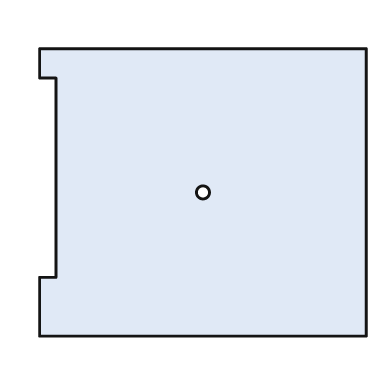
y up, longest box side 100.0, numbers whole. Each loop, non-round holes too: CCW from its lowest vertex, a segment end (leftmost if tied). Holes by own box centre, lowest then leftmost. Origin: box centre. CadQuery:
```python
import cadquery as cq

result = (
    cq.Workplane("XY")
    .moveTo(-50.0, -44.0)
    .lineTo(50.0, -44.0)
    .lineTo(50.0, 44.0)
    .lineTo(-50.0, 44.0)
    .lineTo(-50.0, 35.0)
    .lineTo(-45.0, 35.0)
    .lineTo(-45.0, -26.0)
    .lineTo(-50.0, -26.0)
    .close()
    .moveTo(0.0, 0.0)
    .circle(2.0)
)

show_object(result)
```